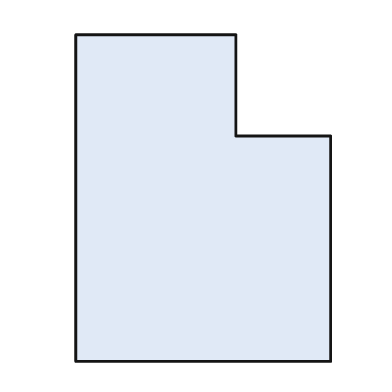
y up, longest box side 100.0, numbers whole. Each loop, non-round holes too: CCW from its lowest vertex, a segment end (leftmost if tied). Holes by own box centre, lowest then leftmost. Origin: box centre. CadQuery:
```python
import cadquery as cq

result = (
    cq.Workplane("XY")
    .moveTo(-39.0, -50.0)
    .lineTo(39.0, -50.0)
    .lineTo(39.0, 19.0)
    .lineTo(10.0, 19.0)
    .lineTo(10.0, 50.0)
    .lineTo(-39.0, 50.0)
    .close()
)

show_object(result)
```